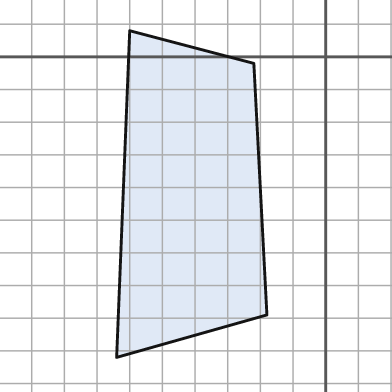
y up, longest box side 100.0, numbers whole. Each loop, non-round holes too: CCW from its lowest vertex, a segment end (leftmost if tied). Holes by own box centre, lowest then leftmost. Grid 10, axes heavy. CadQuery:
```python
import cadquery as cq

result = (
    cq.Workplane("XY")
    .moveTo(-64.0, -92.0)
    .lineTo(-18.0, -79.0)
    .lineTo(-22.0, -2.0)
    .lineTo(-60.0, 8.0)
    .close()
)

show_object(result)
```